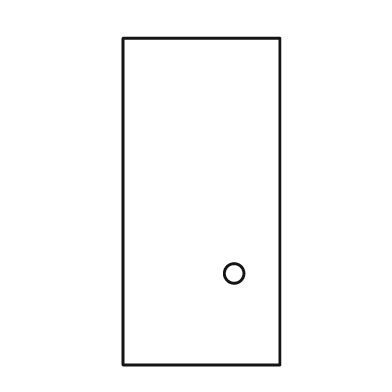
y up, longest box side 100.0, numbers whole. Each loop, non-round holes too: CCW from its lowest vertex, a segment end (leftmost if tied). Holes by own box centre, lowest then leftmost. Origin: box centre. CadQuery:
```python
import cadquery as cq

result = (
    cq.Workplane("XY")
    .moveTo(-24.0, -50.0)
    .lineTo(24.0, -50.0)
    .lineTo(24.0, 50.0)
    .lineTo(-24.0, 50.0)
    .close()
    .moveTo(10.0, -22.0)
    .circle(3.0)
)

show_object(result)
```